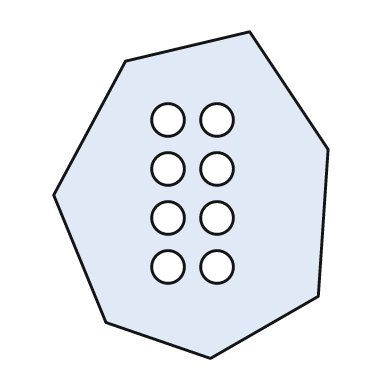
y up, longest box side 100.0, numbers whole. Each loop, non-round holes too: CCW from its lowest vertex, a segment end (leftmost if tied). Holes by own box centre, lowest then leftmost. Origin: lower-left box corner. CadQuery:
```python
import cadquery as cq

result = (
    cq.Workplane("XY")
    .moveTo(48.0, 0.0)
    .lineTo(81.0, 19.0)
    .lineTo(84.0, 64.0)
    .lineTo(60.0, 100.0)
    .lineTo(22.0, 91.0)
    .lineTo(0.0, 50.0)
    .lineTo(16.0, 11.0)
    .close()
    .moveTo(35.0, 28.0)
    .circle(5.0)
    .moveTo(50.0, 28.0)
    .circle(5.0)
    .moveTo(35.0, 43.0)
    .circle(5.0)
    .moveTo(50.0, 43.0)
    .circle(5.0)
    .moveTo(35.0, 58.0)
    .circle(5.0)
    .moveTo(50.0, 58.0)
    .circle(5.0)
    .moveTo(35.0, 73.0)
    .circle(5.0)
    .moveTo(50.0, 73.0)
    .circle(5.0)
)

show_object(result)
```